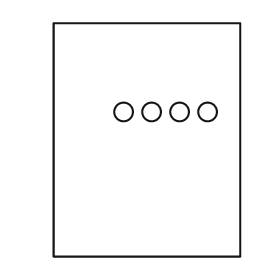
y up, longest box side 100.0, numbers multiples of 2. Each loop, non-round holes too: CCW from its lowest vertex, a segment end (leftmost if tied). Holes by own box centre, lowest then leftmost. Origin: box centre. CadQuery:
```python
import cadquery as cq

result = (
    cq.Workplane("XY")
    .moveTo(-40.0, -50.0)
    .lineTo(40.0, -50.0)
    .lineTo(40.0, 50.0)
    .lineTo(-40.0, 50.0)
    .close()
    .moveTo(-10.0, 12.0)
    .circle(4.0)
    .moveTo(2.0, 12.0)
    .circle(4.0)
    .moveTo(14.0, 12.0)
    .circle(4.0)
    .moveTo(26.0, 12.0)
    .circle(4.0)
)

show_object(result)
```